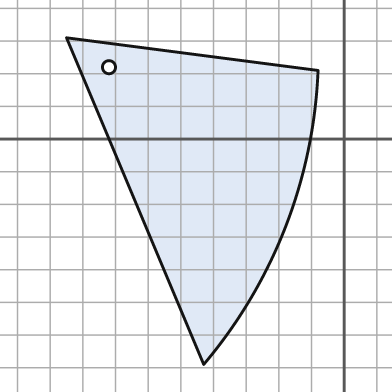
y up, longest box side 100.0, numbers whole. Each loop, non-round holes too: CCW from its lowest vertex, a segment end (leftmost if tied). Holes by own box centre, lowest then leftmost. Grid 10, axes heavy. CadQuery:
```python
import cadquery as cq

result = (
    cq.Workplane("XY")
    .moveTo(-43.0, -69.0)
    .threePointArc((-18.0, -27.0), (-8.0, 21.0))
    .lineTo(-85.0, 31.0)
    .close()
    .moveTo(-72.0, 22.0)
    .circle(2.0)
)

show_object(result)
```